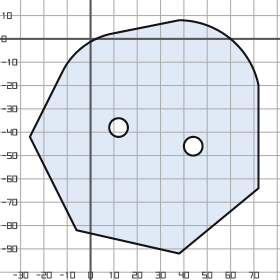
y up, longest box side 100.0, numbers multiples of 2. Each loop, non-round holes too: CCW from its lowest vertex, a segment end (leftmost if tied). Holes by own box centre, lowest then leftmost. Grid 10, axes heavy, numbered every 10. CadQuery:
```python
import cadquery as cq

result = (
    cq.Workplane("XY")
    .moveTo(38.0, -92.0)
    .lineTo(72.0, -64.0)
    .lineTo(72.0, -20.0)
    .threePointArc((60.0, 0.0), (38.0, 8.0))
    .lineTo(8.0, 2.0)
    .threePointArc((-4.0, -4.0), (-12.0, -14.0))
    .lineTo(-26.0, -42.0)
    .lineTo(-6.0, -82.0)
    .close()
    .moveTo(44.0, -46.0)
    .circle(4.0)
    .moveTo(12.0, -38.0)
    .circle(4.0)
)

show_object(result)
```